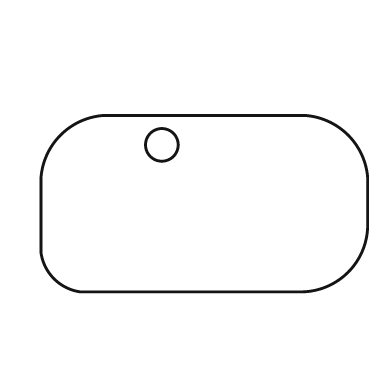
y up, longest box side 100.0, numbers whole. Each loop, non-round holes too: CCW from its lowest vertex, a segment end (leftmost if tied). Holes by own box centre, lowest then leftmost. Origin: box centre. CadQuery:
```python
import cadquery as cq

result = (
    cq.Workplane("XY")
    .moveTo(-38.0, -27.0)
    .lineTo(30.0, -27.0)
    .threePointArc((44.0, -21.0), (50.0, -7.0))
    .lineTo(50.0, 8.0)
    .threePointArc((44.0, 21.0), (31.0, 27.0))
    .lineTo(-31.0, 27.0)
    .threePointArc((-44.0, 21.0), (-50.0, 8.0))
    .lineTo(-50.0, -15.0)
    .threePointArc((-46.0, -23.0), (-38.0, -27.0))
    .close()
    .moveTo(-13.0, 18.0)
    .circle(5.0)
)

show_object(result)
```